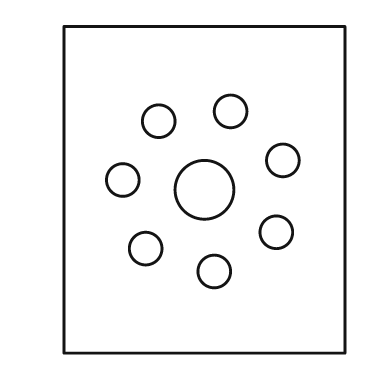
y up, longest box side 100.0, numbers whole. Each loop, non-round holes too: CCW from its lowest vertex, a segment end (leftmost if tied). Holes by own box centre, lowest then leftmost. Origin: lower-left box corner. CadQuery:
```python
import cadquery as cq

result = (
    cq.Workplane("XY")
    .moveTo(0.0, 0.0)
    .lineTo(86.0, 0.0)
    .lineTo(86.0, 100.0)
    .lineTo(0.0, 100.0)
    .close()
    .moveTo(46.0, 25.0)
    .circle(5.0)
    .moveTo(25.0, 32.0)
    .circle(5.0)
    .moveTo(65.0, 37.0)
    .circle(5.0)
    .moveTo(43.0, 50.0)
    .circle(9.0)
    .moveTo(18.0, 53.0)
    .circle(5.0)
    .moveTo(67.0, 59.0)
    .circle(5.0)
    .moveTo(29.0, 71.0)
    .circle(5.0)
    .moveTo(51.0, 74.0)
    .circle(5.0)
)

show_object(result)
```